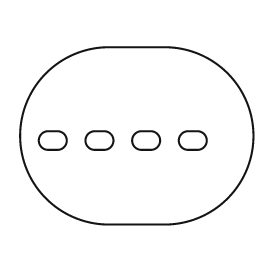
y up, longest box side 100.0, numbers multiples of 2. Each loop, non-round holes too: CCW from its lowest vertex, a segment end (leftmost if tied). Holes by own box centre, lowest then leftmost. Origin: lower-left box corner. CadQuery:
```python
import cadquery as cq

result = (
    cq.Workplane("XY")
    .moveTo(38.0, 0.0)
    .lineTo(62.0, 0.0)
    .threePointArc((100.0, 38.0), (62.0, 76.0))
    .lineTo(38.0, 76.0)
    .threePointArc((0.0, 38.0), (38.0, 0.0))
    .close()
    .moveTo(12.0, 32.0)
    .lineTo(16.0, 32.0)
    .threePointArc((20.0, 36.0), (16.0, 40.0))
    .lineTo(12.0, 40.0)
    .threePointArc((8.0, 36.0), (12.0, 32.0))
    .close()
    .moveTo(32.0, 32.0)
    .lineTo(36.0, 32.0)
    .threePointArc((40.0, 36.0), (36.0, 40.0))
    .lineTo(32.0, 40.0)
    .threePointArc((28.0, 36.0), (32.0, 32.0))
    .close()
    .moveTo(52.0, 32.0)
    .lineTo(56.0, 32.0)
    .threePointArc((60.0, 36.0), (56.0, 40.0))
    .lineTo(52.0, 40.0)
    .threePointArc((48.0, 36.0), (52.0, 32.0))
    .close()
    .moveTo(72.0, 32.0)
    .lineTo(76.0, 32.0)
    .threePointArc((80.0, 36.0), (76.0, 40.0))
    .lineTo(72.0, 40.0)
    .threePointArc((68.0, 36.0), (72.0, 32.0))
    .close()
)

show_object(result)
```